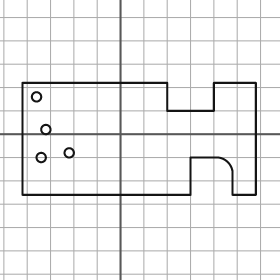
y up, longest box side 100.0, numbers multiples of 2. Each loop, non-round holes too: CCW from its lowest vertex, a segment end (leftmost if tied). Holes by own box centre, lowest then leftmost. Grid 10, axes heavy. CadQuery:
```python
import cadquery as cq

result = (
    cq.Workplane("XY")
    .moveTo(-42.0, -26.0)
    .lineTo(30.0, -26.0)
    .lineTo(30.0, -10.0)
    .lineTo(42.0, -10.0)
    .threePointArc((46.0, -12.0), (48.0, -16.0))
    .lineTo(48.0, -26.0)
    .lineTo(58.0, -26.0)
    .lineTo(58.0, 22.0)
    .lineTo(40.0, 22.0)
    .lineTo(40.0, 10.0)
    .lineTo(20.0, 10.0)
    .lineTo(20.0, 22.0)
    .lineTo(-42.0, 22.0)
    .close()
    .moveTo(-34.0, -10.0)
    .circle(2.0)
    .moveTo(-22.0, -8.0)
    .circle(2.0)
    .moveTo(-32.0, 2.0)
    .circle(2.0)
    .moveTo(-36.0, 16.0)
    .circle(2.0)
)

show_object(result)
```